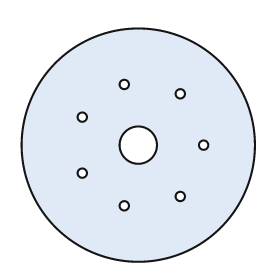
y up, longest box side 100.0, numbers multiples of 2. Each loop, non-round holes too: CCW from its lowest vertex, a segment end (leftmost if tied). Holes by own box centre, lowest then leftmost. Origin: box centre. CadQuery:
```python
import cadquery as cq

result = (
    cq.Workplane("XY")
    .moveTo(0.0, 0.0)
    .circle(50.0)
    .moveTo(-6.0, -26.0)
    .circle(2.0)
    .moveTo(18.0, -22.0)
    .circle(2.0)
    .moveTo(-24.0, -12.0)
    .circle(2.0)
    .moveTo(0.0, 0.0)
    .circle(8.0)
    .moveTo(28.0, 0.0)
    .circle(2.0)
    .moveTo(-24.0, 12.0)
    .circle(2.0)
    .moveTo(18.0, 22.0)
    .circle(2.0)
    .moveTo(-6.0, 26.0)
    .circle(2.0)
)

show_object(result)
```